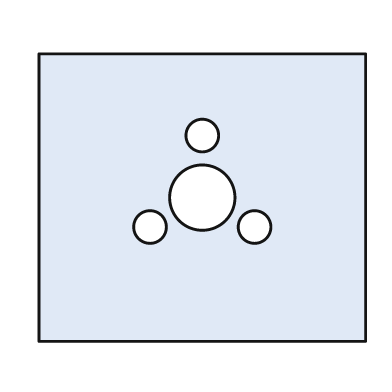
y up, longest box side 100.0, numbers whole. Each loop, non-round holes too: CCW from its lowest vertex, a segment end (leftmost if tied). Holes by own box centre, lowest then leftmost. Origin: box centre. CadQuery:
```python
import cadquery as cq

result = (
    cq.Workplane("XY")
    .moveTo(-50.0, -44.0)
    .lineTo(50.0, -44.0)
    .lineTo(50.0, 44.0)
    .lineTo(-50.0, 44.0)
    .close()
    .moveTo(-16.0, -9.0)
    .circle(5.0)
    .moveTo(16.0, -9.0)
    .circle(5.0)
    .moveTo(0.0, 0.0)
    .circle(10.0)
    .moveTo(0.0, 19.0)
    .circle(5.0)
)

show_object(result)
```